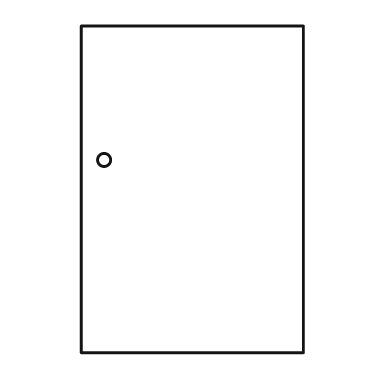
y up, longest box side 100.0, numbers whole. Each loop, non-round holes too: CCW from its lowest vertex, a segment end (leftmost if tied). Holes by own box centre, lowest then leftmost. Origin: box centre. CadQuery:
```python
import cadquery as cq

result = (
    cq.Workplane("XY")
    .moveTo(-34.0, -50.0)
    .lineTo(34.0, -50.0)
    .lineTo(34.0, 50.0)
    .lineTo(-34.0, 50.0)
    .close()
    .moveTo(-27.0, 9.0)
    .circle(2.0)
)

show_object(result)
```